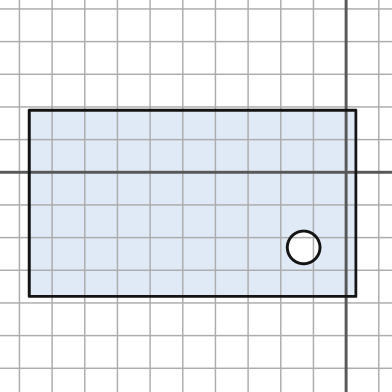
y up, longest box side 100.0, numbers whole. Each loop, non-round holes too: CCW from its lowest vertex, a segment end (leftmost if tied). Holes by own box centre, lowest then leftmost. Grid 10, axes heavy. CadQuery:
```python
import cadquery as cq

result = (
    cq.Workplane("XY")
    .moveTo(-97.0, -38.0)
    .lineTo(3.0, -38.0)
    .lineTo(3.0, 19.0)
    .lineTo(-97.0, 19.0)
    .close()
    .moveTo(-13.0, -23.0)
    .circle(5.0)
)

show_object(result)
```